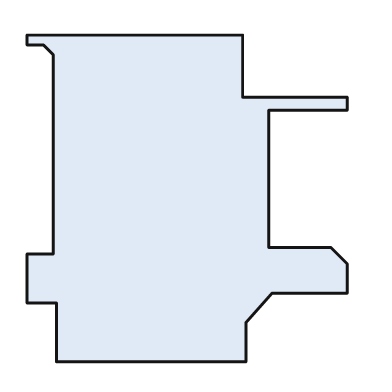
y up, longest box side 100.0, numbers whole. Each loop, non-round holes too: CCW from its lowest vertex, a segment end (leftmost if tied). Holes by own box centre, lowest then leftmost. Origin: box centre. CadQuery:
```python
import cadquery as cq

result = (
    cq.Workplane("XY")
    .moveTo(-40.0, -50.0)
    .lineTo(18.0, -50.0)
    .lineTo(18.0, -38.0)
    .lineTo(26.0, -29.0)
    .lineTo(49.0, -29.0)
    .lineTo(49.0, -20.0)
    .lineTo(44.0, -15.0)
    .lineTo(25.0, -15.0)
    .lineTo(25.0, 27.0)
    .lineTo(49.0, 27.0)
    .lineTo(49.0, 31.0)
    .lineTo(17.0, 31.0)
    .lineTo(17.0, 50.0)
    .lineTo(-49.0, 50.0)
    .lineTo(-49.0, 47.0)
    .lineTo(-44.0, 47.0)
    .lineTo(-41.0, 44.0)
    .lineTo(-41.0, -17.0)
    .lineTo(-49.0, -17.0)
    .lineTo(-49.0, -32.0)
    .lineTo(-40.0, -32.0)
    .close()
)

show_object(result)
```